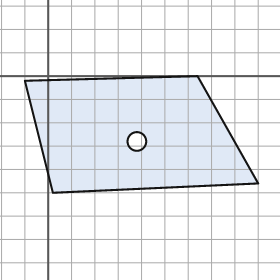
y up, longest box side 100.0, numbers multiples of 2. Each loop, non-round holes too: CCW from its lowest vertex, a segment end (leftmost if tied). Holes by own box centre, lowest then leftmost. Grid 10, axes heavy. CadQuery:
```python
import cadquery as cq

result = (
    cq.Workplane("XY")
    .moveTo(2.0, -50.0)
    .lineTo(90.0, -46.0)
    .lineTo(64.0, 0.0)
    .lineTo(-10.0, -2.0)
    .close()
    .moveTo(38.0, -28.0)
    .circle(4.0)
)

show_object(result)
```